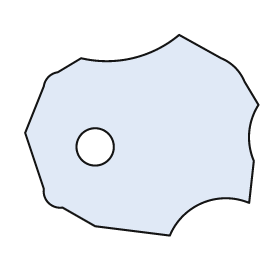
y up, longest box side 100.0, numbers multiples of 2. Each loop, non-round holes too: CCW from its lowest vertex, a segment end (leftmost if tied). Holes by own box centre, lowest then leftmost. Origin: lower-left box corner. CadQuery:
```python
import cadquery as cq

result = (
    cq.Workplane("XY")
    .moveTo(62.0, 0.0)
    .threePointArc((76.0, 14.0), (96.0, 14.0))
    .lineTo(98.0, 32.0)
    .threePointArc((96.0, 44.0), (100.0, 56.0))
    .lineTo(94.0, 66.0)
    .threePointArc((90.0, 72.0), (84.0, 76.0))
    .lineTo(66.0, 86.0)
    .threePointArc((46.0, 76.0), (24.0, 76.0))
    .lineTo(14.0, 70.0)
    .threePointArc((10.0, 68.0), (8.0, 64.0))
    .lineTo(0.0, 44.0)
    .lineTo(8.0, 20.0)
    .threePointArc((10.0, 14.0), (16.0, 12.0))
    .lineTo(30.0, 4.0)
    .close()
    .moveTo(30.0, 38.0)
    .circle(8.0)
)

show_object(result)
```